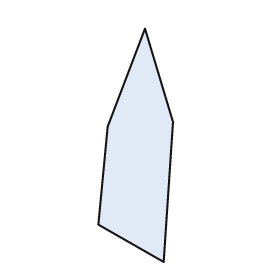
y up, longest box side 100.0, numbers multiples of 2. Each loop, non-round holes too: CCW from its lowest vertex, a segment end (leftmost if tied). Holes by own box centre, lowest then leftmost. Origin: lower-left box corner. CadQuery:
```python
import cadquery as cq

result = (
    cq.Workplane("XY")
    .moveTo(28.0, 0.0)
    .lineTo(32.0, 60.0)
    .lineTo(20.0, 100.0)
    .lineTo(4.0, 58.0)
    .lineTo(0.0, 16.0)
    .close()
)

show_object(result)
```